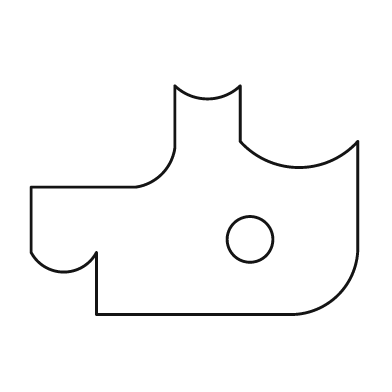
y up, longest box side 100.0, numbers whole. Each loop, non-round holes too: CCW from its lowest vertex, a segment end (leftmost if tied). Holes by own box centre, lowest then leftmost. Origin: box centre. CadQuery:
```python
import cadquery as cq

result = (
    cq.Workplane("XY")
    .moveTo(-30.0, -35.0)
    .lineTo(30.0, -35.0)
    .threePointArc((44.0, -29.0), (50.0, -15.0))
    .lineTo(50.0, 18.0)
    .threePointArc((32.0, 10.0), (14.0, 18.0))
    .lineTo(14.0, 35.0)
    .threePointArc((4.0, 31.0), (-6.0, 35.0))
    .lineTo(-6.0, 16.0)
    .threePointArc((-10.0, 8.0), (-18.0, 4.0))
    .lineTo(-50.0, 4.0)
    .lineTo(-50.0, -16.0)
    .threePointArc((-40.0, -22.0), (-30.0, -16.0))
    .close()
    .moveTo(17.0, -12.0)
    .circle(7.0)
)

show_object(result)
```